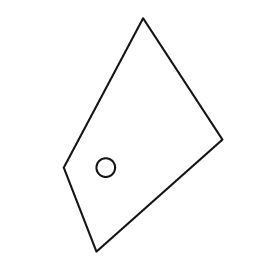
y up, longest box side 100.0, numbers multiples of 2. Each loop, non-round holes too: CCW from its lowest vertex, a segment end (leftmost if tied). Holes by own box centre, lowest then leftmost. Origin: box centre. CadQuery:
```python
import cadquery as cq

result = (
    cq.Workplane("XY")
    .moveTo(-20.0, -50.0)
    .lineTo(34.0, -2.0)
    .lineTo(0.0, 50.0)
    .lineTo(-34.0, -14.0)
    .close()
    .moveTo(-16.0, -14.0)
    .circle(4.0)
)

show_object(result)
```